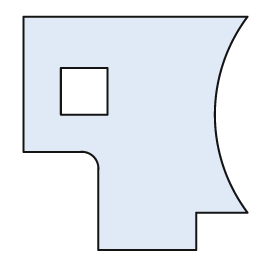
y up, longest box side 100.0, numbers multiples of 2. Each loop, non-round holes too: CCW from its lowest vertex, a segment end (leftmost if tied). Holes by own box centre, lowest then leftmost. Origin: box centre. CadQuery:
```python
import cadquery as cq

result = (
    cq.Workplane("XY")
    .moveTo(-16.0, -50.0)
    .lineTo(26.0, -50.0)
    .lineTo(26.0, -34.0)
    .lineTo(48.0, -34.0)
    .threePointArc((34.0, 8.0), (48.0, 50.0))
    .lineTo(-48.0, 50.0)
    .lineTo(-48.0, -8.0)
    .lineTo(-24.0, -8.0)
    .threePointArc((-18.0, -10.0), (-16.0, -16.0))
    .close()
    .moveTo(-32.0, 8.0)
    .lineTo(-12.0, 8.0)
    .lineTo(-12.0, 28.0)
    .lineTo(-32.0, 28.0)
    .close()
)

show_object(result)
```